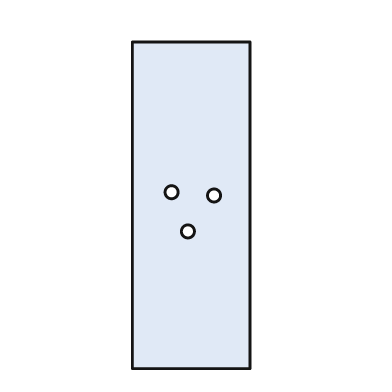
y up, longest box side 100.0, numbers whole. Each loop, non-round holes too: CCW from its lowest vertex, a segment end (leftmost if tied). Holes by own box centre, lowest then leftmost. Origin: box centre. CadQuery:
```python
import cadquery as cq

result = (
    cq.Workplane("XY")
    .moveTo(-18.0, -50.0)
    .lineTo(18.0, -50.0)
    .lineTo(18.0, 50.0)
    .lineTo(-18.0, 50.0)
    .close()
    .moveTo(-1.0, -8.0)
    .circle(2.0)
    .moveTo(7.0, 3.0)
    .circle(2.0)
    .moveTo(-6.0, 4.0)
    .circle(2.0)
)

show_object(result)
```